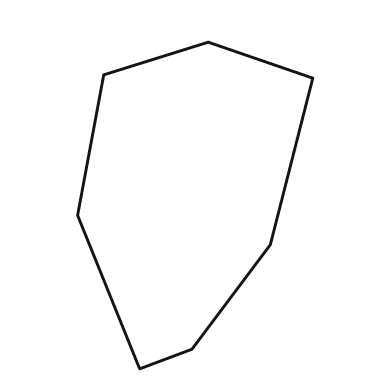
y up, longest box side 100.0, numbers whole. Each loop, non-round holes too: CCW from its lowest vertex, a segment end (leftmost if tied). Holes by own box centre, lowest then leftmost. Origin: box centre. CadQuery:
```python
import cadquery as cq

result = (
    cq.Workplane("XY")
    .moveTo(-17.0, -50.0)
    .lineTo(-1.0, -44.0)
    .lineTo(23.0, -12.0)
    .lineTo(36.0, 39.0)
    .lineTo(4.0, 50.0)
    .lineTo(-28.0, 40.0)
    .lineTo(-36.0, -3.0)
    .close()
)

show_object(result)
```